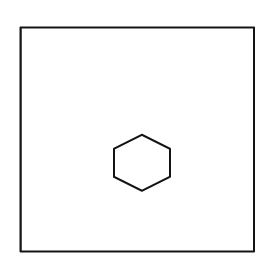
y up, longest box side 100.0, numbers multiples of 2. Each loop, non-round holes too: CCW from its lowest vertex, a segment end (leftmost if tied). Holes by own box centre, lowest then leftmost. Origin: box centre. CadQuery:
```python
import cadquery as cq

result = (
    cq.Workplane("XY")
    .moveTo(-50.0, -48.0)
    .lineTo(50.0, -48.0)
    .lineTo(50.0, 48.0)
    .lineTo(-50.0, 48.0)
    .close()
    .moveTo(2.0, -22.0)
    .lineTo(14.0, -16.0)
    .lineTo(14.0, -4.0)
    .lineTo(2.0, 2.0)
    .lineTo(-10.0, -4.0)
    .lineTo(-10.0, -16.0)
    .close()
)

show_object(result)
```